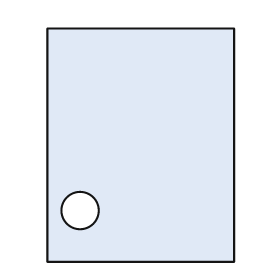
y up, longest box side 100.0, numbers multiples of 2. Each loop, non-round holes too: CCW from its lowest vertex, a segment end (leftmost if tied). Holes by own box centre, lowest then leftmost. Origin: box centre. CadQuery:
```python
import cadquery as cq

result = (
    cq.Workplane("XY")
    .moveTo(-40.0, -50.0)
    .lineTo(40.0, -50.0)
    .lineTo(40.0, 50.0)
    .lineTo(-40.0, 50.0)
    .close()
    .moveTo(-26.0, -28.0)
    .circle(8.0)
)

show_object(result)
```